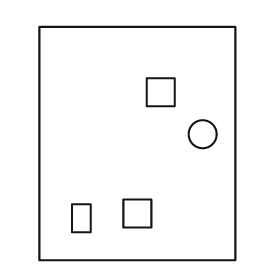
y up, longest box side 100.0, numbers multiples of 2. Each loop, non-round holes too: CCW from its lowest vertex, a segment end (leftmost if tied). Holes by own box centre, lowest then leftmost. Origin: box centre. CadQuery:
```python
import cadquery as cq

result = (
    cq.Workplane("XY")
    .moveTo(-42.0, -50.0)
    .lineTo(42.0, -50.0)
    .lineTo(42.0, 50.0)
    .lineTo(-42.0, 50.0)
    .close()
    .moveTo(-28.0, -38.0)
    .lineTo(-20.0, -38.0)
    .lineTo(-20.0, -26.0)
    .lineTo(-28.0, -26.0)
    .close()
    .moveTo(-6.0, -36.0)
    .lineTo(6.0, -36.0)
    .lineTo(6.0, -24.0)
    .lineTo(-6.0, -24.0)
    .close()
    .moveTo(28.0, 4.0)
    .circle(6.0)
    .moveTo(4.0, 16.0)
    .lineTo(16.0, 16.0)
    .lineTo(16.0, 28.0)
    .lineTo(4.0, 28.0)
    .close()
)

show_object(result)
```